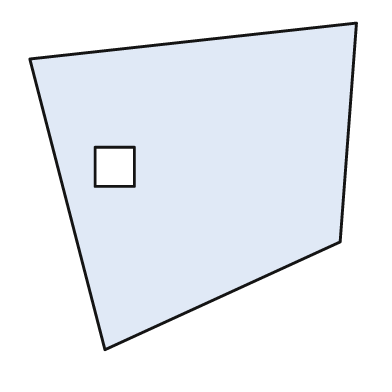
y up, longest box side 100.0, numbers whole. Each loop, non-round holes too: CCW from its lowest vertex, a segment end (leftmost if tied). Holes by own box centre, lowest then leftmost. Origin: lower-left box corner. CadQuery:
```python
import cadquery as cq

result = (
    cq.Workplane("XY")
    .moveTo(23.0, 0.0)
    .lineTo(95.0, 33.0)
    .lineTo(100.0, 100.0)
    .lineTo(0.0, 89.0)
    .close()
    .moveTo(20.0, 50.0)
    .lineTo(32.0, 50.0)
    .lineTo(32.0, 62.0)
    .lineTo(20.0, 62.0)
    .close()
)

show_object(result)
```